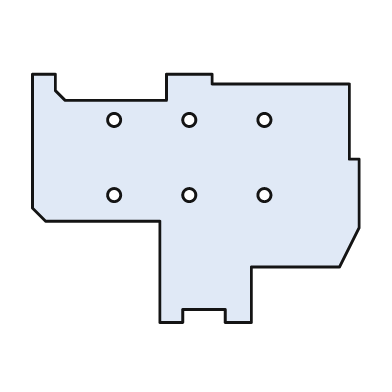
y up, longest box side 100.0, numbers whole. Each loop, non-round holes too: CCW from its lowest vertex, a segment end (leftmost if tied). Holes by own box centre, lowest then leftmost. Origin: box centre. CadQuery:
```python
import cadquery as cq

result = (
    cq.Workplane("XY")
    .moveTo(-11.0, -38.0)
    .lineTo(-4.0, -38.0)
    .lineTo(-4.0, -34.0)
    .lineTo(9.0, -34.0)
    .lineTo(9.0, -38.0)
    .lineTo(17.0, -38.0)
    .lineTo(17.0, -21.0)
    .lineTo(44.0, -21.0)
    .lineTo(50.0, -9.0)
    .lineTo(50.0, 12.0)
    .lineTo(47.0, 12.0)
    .lineTo(47.0, 35.0)
    .lineTo(5.0, 35.0)
    .lineTo(5.0, 38.0)
    .lineTo(-9.0, 38.0)
    .lineTo(-9.0, 30.0)
    .lineTo(-40.0, 30.0)
    .lineTo(-43.0, 33.0)
    .lineTo(-43.0, 38.0)
    .lineTo(-50.0, 38.0)
    .lineTo(-50.0, -3.0)
    .lineTo(-46.0, -7.0)
    .lineTo(-11.0, -7.0)
    .close()
    .moveTo(-25.0, 1.0)
    .circle(2.0)
    .moveTo(-2.0, 1.0)
    .circle(2.0)
    .moveTo(21.0, 1.0)
    .circle(2.0)
    .moveTo(-25.0, 24.0)
    .circle(2.0)
    .moveTo(-2.0, 24.0)
    .circle(2.0)
    .moveTo(21.0, 24.0)
    .circle(2.0)
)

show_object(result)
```